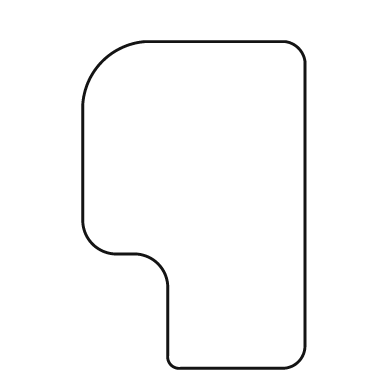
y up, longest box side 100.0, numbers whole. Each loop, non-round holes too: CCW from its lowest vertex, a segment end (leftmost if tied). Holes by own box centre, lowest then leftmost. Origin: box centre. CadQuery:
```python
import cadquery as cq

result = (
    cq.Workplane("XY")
    .moveTo(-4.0, -50.0)
    .lineTo(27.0, -50.0)
    .threePointArc((32.0, -48.0), (34.0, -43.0))
    .lineTo(34.0, 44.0)
    .threePointArc((32.0, 48.0), (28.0, 50.0))
    .lineTo(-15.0, 50.0)
    .threePointArc((-28.0, 44.0), (-34.0, 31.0))
    .lineTo(-34.0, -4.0)
    .threePointArc((-31.0, -12.0), (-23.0, -15.0))
    .lineTo(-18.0, -15.0)
    .threePointArc((-11.0, -18.0), (-8.0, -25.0))
    .lineTo(-8.0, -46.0)
    .threePointArc((-7.0, -49.0), (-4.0, -50.0))
    .close()
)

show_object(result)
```